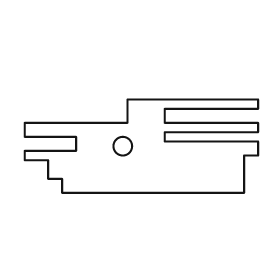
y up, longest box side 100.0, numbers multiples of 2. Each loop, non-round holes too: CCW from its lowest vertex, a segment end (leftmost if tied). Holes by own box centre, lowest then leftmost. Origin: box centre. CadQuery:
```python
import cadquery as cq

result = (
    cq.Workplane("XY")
    .moveTo(-34.0, -20.0)
    .lineTo(44.0, -20.0)
    .lineTo(44.0, -4.0)
    .lineTo(50.0, -4.0)
    .lineTo(50.0, 2.0)
    .lineTo(10.0, 2.0)
    .lineTo(10.0, 6.0)
    .lineTo(50.0, 6.0)
    .lineTo(50.0, 10.0)
    .lineTo(10.0, 10.0)
    .lineTo(10.0, 16.0)
    .lineTo(50.0, 16.0)
    .lineTo(50.0, 20.0)
    .lineTo(-6.0, 20.0)
    .lineTo(-6.0, 10.0)
    .lineTo(-50.0, 10.0)
    .lineTo(-50.0, 4.0)
    .lineTo(-28.0, 4.0)
    .lineTo(-28.0, -2.0)
    .lineTo(-50.0, -2.0)
    .lineTo(-50.0, -6.0)
    .lineTo(-40.0, -6.0)
    .lineTo(-40.0, -14.0)
    .lineTo(-34.0, -14.0)
    .close()
    .moveTo(-8.0, 0.0)
    .circle(4.0)
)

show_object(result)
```